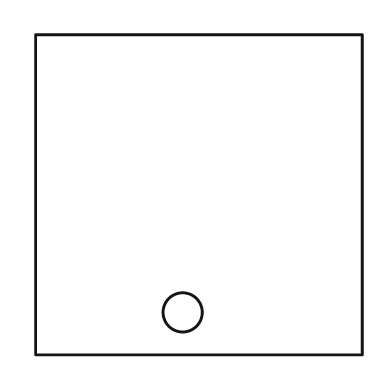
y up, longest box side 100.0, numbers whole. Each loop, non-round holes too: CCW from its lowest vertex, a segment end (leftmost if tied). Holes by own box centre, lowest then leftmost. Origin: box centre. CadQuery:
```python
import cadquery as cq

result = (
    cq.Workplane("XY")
    .moveTo(-50.0, -49.0)
    .lineTo(50.0, -49.0)
    .lineTo(50.0, 49.0)
    .lineTo(-50.0, 49.0)
    .close()
    .moveTo(-5.0, -36.0)
    .circle(6.0)
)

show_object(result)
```